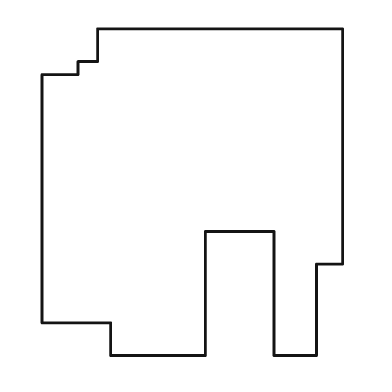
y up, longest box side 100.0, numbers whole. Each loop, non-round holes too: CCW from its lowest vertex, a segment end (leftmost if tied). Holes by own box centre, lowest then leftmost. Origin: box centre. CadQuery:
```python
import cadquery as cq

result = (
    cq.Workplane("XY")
    .moveTo(-25.0, -50.0)
    .lineTo(4.0, -50.0)
    .lineTo(4.0, -12.0)
    .lineTo(25.0, -12.0)
    .lineTo(25.0, -50.0)
    .lineTo(38.0, -50.0)
    .lineTo(38.0, -22.0)
    .lineTo(46.0, -22.0)
    .lineTo(46.0, 50.0)
    .lineTo(-29.0, 50.0)
    .lineTo(-29.0, 40.0)
    .lineTo(-35.0, 40.0)
    .lineTo(-35.0, 36.0)
    .lineTo(-46.0, 36.0)
    .lineTo(-46.0, -40.0)
    .lineTo(-25.0, -40.0)
    .close()
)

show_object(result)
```